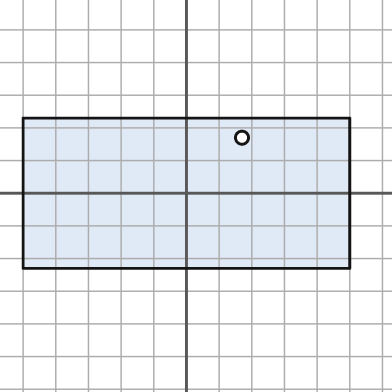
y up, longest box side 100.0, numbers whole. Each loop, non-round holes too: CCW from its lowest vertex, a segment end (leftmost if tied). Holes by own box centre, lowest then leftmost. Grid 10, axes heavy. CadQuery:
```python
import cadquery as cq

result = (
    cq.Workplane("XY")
    .moveTo(-50.0, -23.0)
    .lineTo(50.0, -23.0)
    .lineTo(50.0, 23.0)
    .lineTo(-50.0, 23.0)
    .close()
    .moveTo(17.0, 17.0)
    .circle(2.0)
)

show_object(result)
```